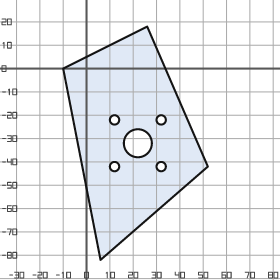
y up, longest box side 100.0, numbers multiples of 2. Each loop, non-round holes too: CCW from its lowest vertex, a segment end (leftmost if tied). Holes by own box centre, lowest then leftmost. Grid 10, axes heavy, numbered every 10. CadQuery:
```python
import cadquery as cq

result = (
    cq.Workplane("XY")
    .moveTo(6.0, -82.0)
    .lineTo(52.0, -42.0)
    .lineTo(26.0, 18.0)
    .lineTo(-10.0, 0.0)
    .close()
    .moveTo(12.0, -42.0)
    .circle(2.0)
    .moveTo(32.0, -42.0)
    .circle(2.0)
    .moveTo(22.0, -32.0)
    .circle(6.0)
    .moveTo(12.0, -22.0)
    .circle(2.0)
    .moveTo(32.0, -22.0)
    .circle(2.0)
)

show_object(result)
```